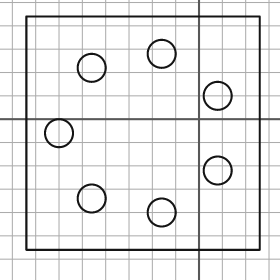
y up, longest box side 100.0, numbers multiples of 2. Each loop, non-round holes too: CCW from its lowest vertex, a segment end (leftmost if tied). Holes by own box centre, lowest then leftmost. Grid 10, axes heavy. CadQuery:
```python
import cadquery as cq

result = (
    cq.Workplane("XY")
    .moveTo(-74.0, -56.0)
    .lineTo(26.0, -56.0)
    .lineTo(26.0, 44.0)
    .lineTo(-74.0, 44.0)
    .close()
    .moveTo(-16.0, -40.0)
    .circle(6.0)
    .moveTo(-46.0, -34.0)
    .circle(6.0)
    .moveTo(8.0, -22.0)
    .circle(6.0)
    .moveTo(-60.0, -6.0)
    .circle(6.0)
    .moveTo(8.0, 10.0)
    .circle(6.0)
    .moveTo(-46.0, 22.0)
    .circle(6.0)
    .moveTo(-16.0, 28.0)
    .circle(6.0)
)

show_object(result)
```